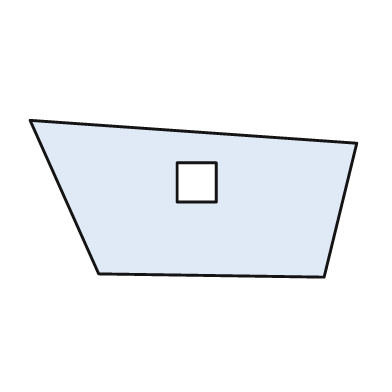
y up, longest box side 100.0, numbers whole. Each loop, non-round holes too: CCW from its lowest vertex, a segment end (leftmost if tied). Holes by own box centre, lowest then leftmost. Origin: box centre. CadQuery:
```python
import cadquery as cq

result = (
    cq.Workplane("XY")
    .moveTo(40.0, -24.0)
    .lineTo(50.0, 17.0)
    .lineTo(-50.0, 24.0)
    .lineTo(-29.0, -23.0)
    .close()
    .moveTo(-5.0, -1.0)
    .lineTo(7.0, -1.0)
    .lineTo(7.0, 11.0)
    .lineTo(-5.0, 11.0)
    .close()
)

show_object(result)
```